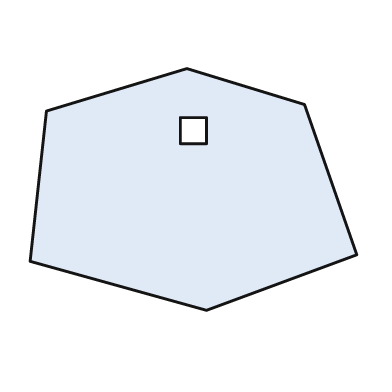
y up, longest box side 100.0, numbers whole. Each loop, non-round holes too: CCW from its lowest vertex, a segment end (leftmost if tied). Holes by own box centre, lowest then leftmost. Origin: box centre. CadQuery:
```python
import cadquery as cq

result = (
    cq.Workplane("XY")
    .moveTo(4.0, -37.0)
    .lineTo(50.0, -20.0)
    .lineTo(34.0, 26.0)
    .lineTo(-2.0, 37.0)
    .lineTo(-45.0, 24.0)
    .lineTo(-50.0, -22.0)
    .close()
    .moveTo(-4.0, 14.0)
    .lineTo(4.0, 14.0)
    .lineTo(4.0, 22.0)
    .lineTo(-4.0, 22.0)
    .close()
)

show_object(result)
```